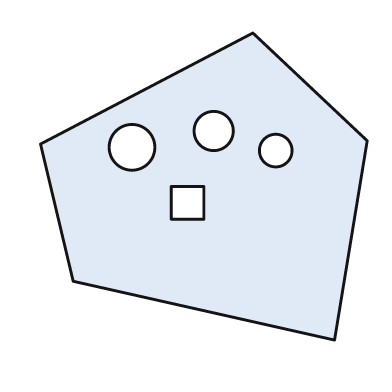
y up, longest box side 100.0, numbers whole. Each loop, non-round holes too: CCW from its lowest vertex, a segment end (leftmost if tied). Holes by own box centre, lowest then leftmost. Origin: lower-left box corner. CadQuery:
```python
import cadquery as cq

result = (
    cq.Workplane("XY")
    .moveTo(90.0, 0.0)
    .lineTo(100.0, 61.0)
    .lineTo(65.0, 94.0)
    .lineTo(0.0, 60.0)
    .lineTo(10.0, 18.0)
    .close()
    .moveTo(40.0, 37.0)
    .lineTo(50.0, 37.0)
    .lineTo(50.0, 47.0)
    .lineTo(40.0, 47.0)
    .close()
    .moveTo(72.0, 58.0)
    .circle(5.0)
    .moveTo(28.0, 59.0)
    .circle(7.0)
    .moveTo(53.0, 64.0)
    .circle(6.0)
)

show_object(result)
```